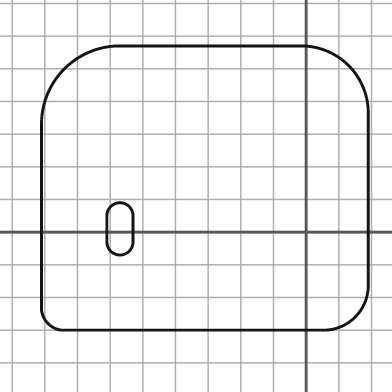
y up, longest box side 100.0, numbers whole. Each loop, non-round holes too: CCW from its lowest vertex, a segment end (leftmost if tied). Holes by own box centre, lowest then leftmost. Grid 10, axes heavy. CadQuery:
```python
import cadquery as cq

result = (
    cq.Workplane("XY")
    .moveTo(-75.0, -30.0)
    .lineTo(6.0, -30.0)
    .threePointArc((15.0, -26.0), (19.0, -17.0))
    .lineTo(19.0, 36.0)
    .threePointArc((13.0, 51.0), (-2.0, 57.0))
    .lineTo(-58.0, 57.0)
    .threePointArc((-74.0, 50.0), (-81.0, 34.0))
    .lineTo(-81.0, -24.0)
    .threePointArc((-79.0, -28.0), (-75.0, -30.0))
    .close()
    .moveTo(-61.0, -3.0)
    .threePointArc((-57.0, -7.0), (-53.0, -3.0))
    .lineTo(-53.0, 5.0)
    .threePointArc((-57.0, 9.0), (-61.0, 5.0))
    .close()
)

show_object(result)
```